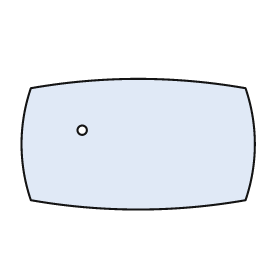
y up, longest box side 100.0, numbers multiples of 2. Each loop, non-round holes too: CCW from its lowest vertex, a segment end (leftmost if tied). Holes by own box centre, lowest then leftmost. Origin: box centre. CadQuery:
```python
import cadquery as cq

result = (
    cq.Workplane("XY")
    .moveTo(-46.0, -24.0)
    .threePointArc((0.0, -28.0), (46.0, -24.0))
    .threePointArc((50.0, 0.0), (46.0, 24.0))
    .threePointArc((0.0, 28.0), (-46.0, 24.0))
    .threePointArc((-50.0, 0.0), (-46.0, -24.0))
    .close()
    .moveTo(-24.0, 6.0)
    .circle(2.0)
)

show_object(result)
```